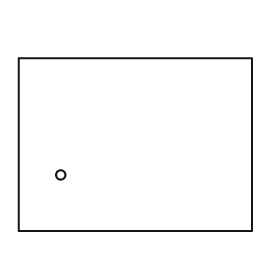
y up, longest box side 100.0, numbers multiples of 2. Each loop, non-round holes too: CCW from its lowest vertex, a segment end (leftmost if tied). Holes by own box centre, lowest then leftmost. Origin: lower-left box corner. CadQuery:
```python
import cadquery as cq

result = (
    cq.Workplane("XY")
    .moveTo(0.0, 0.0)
    .lineTo(100.0, 0.0)
    .lineTo(100.0, 74.0)
    .lineTo(0.0, 74.0)
    .close()
    .moveTo(18.0, 24.0)
    .circle(2.0)
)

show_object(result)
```